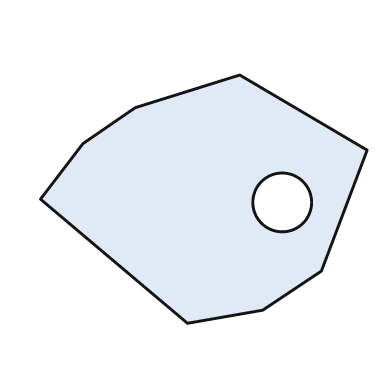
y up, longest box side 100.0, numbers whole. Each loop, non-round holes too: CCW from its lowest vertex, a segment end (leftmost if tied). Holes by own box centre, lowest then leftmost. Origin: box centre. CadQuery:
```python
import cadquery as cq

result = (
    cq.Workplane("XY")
    .moveTo(-5.0, -38.0)
    .lineTo(18.0, -34.0)
    .lineTo(36.0, -22.0)
    .lineTo(50.0, 15.0)
    .lineTo(11.0, 38.0)
    .lineTo(-21.0, 28.0)
    .lineTo(-37.0, 17.0)
    .lineTo(-50.0, 0.0)
    .close()
    .moveTo(24.0, -1.0)
    .circle(9.0)
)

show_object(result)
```